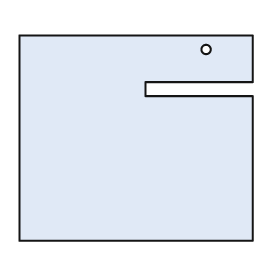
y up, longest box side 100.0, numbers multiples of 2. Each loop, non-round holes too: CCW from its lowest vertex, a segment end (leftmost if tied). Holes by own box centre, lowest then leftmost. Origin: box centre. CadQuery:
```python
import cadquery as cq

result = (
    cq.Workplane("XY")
    .moveTo(-50.0, -44.0)
    .lineTo(50.0, -44.0)
    .lineTo(50.0, 18.0)
    .lineTo(4.0, 18.0)
    .lineTo(4.0, 24.0)
    .lineTo(50.0, 24.0)
    .lineTo(50.0, 44.0)
    .lineTo(-50.0, 44.0)
    .close()
    .moveTo(30.0, 38.0)
    .circle(2.0)
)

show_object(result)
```